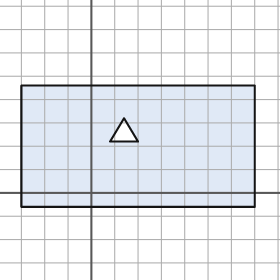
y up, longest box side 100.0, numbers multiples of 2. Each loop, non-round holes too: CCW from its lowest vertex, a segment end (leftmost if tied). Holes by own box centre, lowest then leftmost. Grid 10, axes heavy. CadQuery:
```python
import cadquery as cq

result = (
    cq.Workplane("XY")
    .moveTo(-30.0, -6.0)
    .lineTo(70.0, -6.0)
    .lineTo(70.0, 46.0)
    .lineTo(-30.0, 46.0)
    .close()
    .moveTo(8.0, 22.0)
    .lineTo(20.0, 22.0)
    .lineTo(14.0, 32.0)
    .close()
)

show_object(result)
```